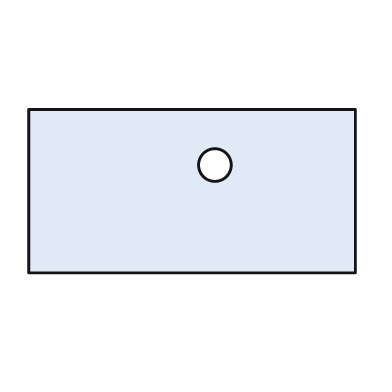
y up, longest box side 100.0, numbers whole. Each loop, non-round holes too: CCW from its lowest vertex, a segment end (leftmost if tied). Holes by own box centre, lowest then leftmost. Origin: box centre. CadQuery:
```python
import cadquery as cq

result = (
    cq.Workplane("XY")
    .moveTo(-50.0, -25.0)
    .lineTo(50.0, -25.0)
    .lineTo(50.0, 25.0)
    .lineTo(-50.0, 25.0)
    .close()
    .moveTo(7.0, 8.0)
    .circle(5.0)
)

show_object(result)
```